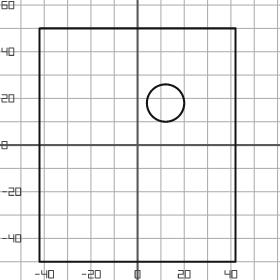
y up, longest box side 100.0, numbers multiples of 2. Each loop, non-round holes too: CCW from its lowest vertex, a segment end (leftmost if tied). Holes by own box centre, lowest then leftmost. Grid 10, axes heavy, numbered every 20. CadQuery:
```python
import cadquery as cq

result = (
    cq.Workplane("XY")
    .moveTo(-42.0, -50.0)
    .lineTo(42.0, -50.0)
    .lineTo(42.0, 50.0)
    .lineTo(-42.0, 50.0)
    .close()
    .moveTo(12.0, 18.0)
    .circle(8.0)
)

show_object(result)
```